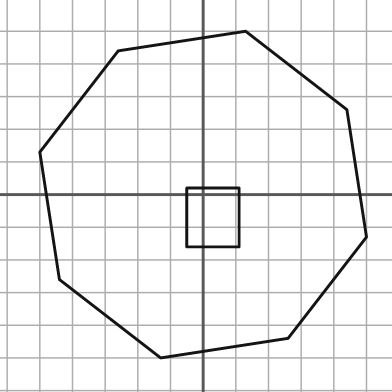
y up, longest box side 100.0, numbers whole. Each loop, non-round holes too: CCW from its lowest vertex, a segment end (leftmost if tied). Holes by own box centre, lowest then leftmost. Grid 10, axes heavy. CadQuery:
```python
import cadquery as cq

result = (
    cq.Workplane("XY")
    .moveTo(-13.0, -50.0)
    .lineTo(26.0, -44.0)
    .lineTo(50.0, -13.0)
    .lineTo(44.0, 26.0)
    .lineTo(13.0, 50.0)
    .lineTo(-26.0, 44.0)
    .lineTo(-50.0, 13.0)
    .lineTo(-44.0, -26.0)
    .close()
    .moveTo(-5.0, -16.0)
    .lineTo(11.0, -16.0)
    .lineTo(11.0, 2.0)
    .lineTo(-5.0, 2.0)
    .close()
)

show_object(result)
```